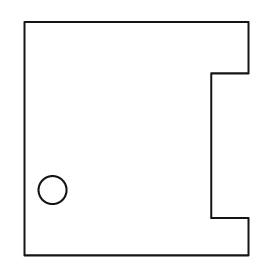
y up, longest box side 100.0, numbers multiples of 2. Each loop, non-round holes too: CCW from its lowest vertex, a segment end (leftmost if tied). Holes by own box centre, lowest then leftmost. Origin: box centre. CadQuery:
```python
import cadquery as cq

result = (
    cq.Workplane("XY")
    .moveTo(-48.0, -50.0)
    .lineTo(48.0, -50.0)
    .lineTo(48.0, -34.0)
    .lineTo(32.0, -34.0)
    .lineTo(32.0, 28.0)
    .lineTo(48.0, 28.0)
    .lineTo(48.0, 50.0)
    .lineTo(-48.0, 50.0)
    .close()
    .moveTo(-36.0, -22.0)
    .circle(6.0)
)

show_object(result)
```